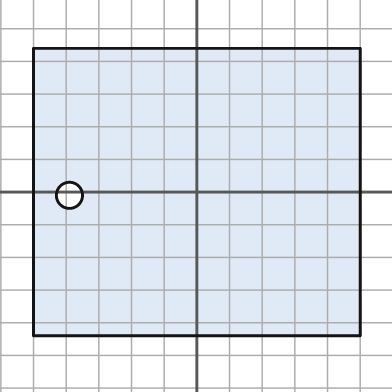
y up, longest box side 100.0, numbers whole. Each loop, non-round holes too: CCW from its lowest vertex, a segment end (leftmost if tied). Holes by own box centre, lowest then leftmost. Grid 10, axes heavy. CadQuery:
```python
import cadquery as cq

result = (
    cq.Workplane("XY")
    .moveTo(-50.0, -44.0)
    .lineTo(50.0, -44.0)
    .lineTo(50.0, 44.0)
    .lineTo(-50.0, 44.0)
    .close()
    .moveTo(-39.0, -1.0)
    .circle(4.0)
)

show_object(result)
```